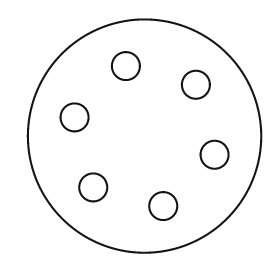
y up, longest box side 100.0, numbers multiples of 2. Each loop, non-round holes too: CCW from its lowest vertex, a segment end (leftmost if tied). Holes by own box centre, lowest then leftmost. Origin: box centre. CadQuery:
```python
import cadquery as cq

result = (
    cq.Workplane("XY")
    .moveTo(0.0, 0.0)
    .circle(50.0)
    .moveTo(8.0, -30.0)
    .circle(6.0)
    .moveTo(-22.0, -22.0)
    .circle(6.0)
    .moveTo(30.0, -8.0)
    .circle(6.0)
    .moveTo(-30.0, 8.0)
    .circle(6.0)
    .moveTo(22.0, 22.0)
    .circle(6.0)
    .moveTo(-8.0, 30.0)
    .circle(6.0)
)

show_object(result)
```